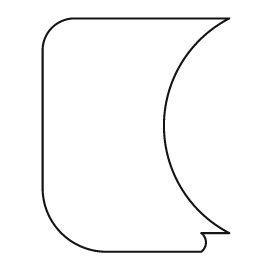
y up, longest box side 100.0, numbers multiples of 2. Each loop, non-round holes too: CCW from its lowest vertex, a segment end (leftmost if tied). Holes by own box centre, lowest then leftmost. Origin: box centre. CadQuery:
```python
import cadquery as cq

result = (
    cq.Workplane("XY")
    .moveTo(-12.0, -50.0)
    .lineTo(28.0, -50.0)
    .threePointArc((30.0, -46.0), (28.0, -42.0))
    .lineTo(40.0, -42.0)
    .threePointArc((12.0, 4.0), (40.0, 50.0))
    .lineTo(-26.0, 50.0)
    .threePointArc((-36.0, 46.0), (-40.0, 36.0))
    .lineTo(-40.0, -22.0)
    .threePointArc((-32.0, -42.0), (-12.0, -50.0))
    .close()
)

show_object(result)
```